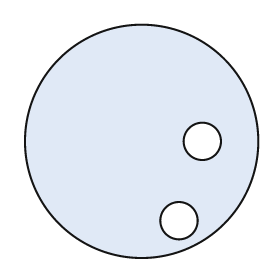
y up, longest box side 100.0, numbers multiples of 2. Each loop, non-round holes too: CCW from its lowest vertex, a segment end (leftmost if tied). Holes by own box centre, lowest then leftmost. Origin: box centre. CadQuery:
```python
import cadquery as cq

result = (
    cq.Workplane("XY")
    .moveTo(0.0, 0.0)
    .circle(50.0)
    .moveTo(16.0, -34.0)
    .circle(8.0)
    .moveTo(26.0, 0.0)
    .circle(8.0)
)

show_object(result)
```